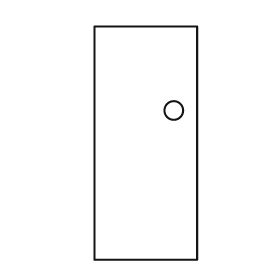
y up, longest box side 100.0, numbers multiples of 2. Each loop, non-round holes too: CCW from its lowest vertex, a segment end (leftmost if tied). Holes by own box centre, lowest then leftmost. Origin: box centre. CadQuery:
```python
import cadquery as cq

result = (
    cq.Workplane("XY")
    .moveTo(-22.0, -50.0)
    .lineTo(22.0, -50.0)
    .lineTo(22.0, 50.0)
    .lineTo(-22.0, 50.0)
    .close()
    .moveTo(12.0, 14.0)
    .circle(4.0)
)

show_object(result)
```